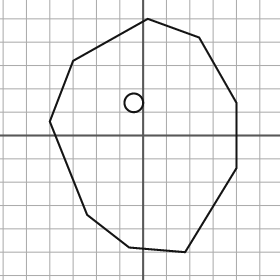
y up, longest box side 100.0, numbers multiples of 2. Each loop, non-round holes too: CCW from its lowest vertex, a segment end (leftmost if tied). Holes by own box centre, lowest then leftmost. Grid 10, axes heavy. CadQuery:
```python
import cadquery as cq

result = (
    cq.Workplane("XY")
    .moveTo(18.0, -50.0)
    .lineTo(40.0, -14.0)
    .lineTo(40.0, 14.0)
    .lineTo(24.0, 42.0)
    .lineTo(2.0, 50.0)
    .lineTo(-30.0, 32.0)
    .lineTo(-40.0, 6.0)
    .lineTo(-24.0, -34.0)
    .lineTo(-6.0, -48.0)
    .close()
    .moveTo(-4.0, 14.0)
    .circle(4.0)
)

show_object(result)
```